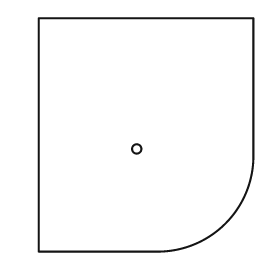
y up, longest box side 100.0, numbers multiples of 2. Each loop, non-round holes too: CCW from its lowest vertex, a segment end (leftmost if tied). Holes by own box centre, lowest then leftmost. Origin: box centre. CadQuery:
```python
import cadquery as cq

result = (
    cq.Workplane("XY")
    .moveTo(-46.0, -50.0)
    .lineTo(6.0, -50.0)
    .threePointArc((34.0, -38.0), (46.0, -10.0))
    .lineTo(46.0, 50.0)
    .lineTo(-46.0, 50.0)
    .close()
    .moveTo(-4.0, -6.0)
    .circle(2.0)
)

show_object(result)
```